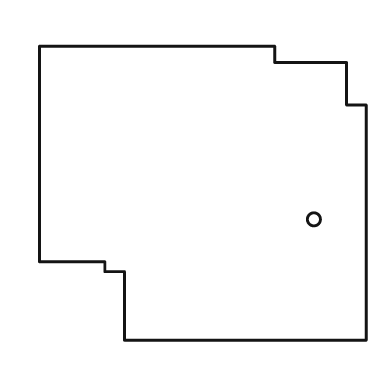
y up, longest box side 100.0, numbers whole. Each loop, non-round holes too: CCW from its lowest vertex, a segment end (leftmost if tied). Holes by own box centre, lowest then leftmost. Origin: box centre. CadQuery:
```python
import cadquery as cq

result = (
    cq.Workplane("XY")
    .moveTo(-24.0, -45.0)
    .lineTo(50.0, -45.0)
    .lineTo(50.0, 27.0)
    .lineTo(44.0, 27.0)
    .lineTo(44.0, 40.0)
    .lineTo(22.0, 40.0)
    .lineTo(22.0, 45.0)
    .lineTo(-50.0, 45.0)
    .lineTo(-50.0, -21.0)
    .lineTo(-30.0, -21.0)
    .lineTo(-30.0, -24.0)
    .lineTo(-24.0, -24.0)
    .close()
    .moveTo(34.0, -8.0)
    .circle(2.0)
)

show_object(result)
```